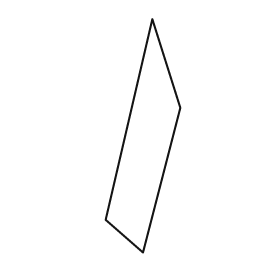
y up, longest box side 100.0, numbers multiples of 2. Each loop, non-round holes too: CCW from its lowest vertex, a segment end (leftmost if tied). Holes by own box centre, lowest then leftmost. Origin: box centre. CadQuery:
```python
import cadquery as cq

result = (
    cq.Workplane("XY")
    .moveTo(0.0, -50.0)
    .lineTo(16.0, 12.0)
    .lineTo(4.0, 50.0)
    .lineTo(-16.0, -36.0)
    .close()
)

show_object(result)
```